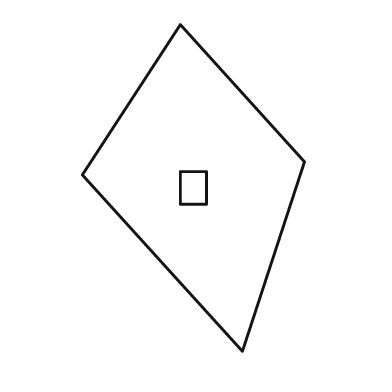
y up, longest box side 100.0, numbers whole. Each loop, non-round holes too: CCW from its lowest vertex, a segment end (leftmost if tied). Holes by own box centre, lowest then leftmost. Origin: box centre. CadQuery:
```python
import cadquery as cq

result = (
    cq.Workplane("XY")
    .moveTo(15.0, -50.0)
    .lineTo(34.0, 8.0)
    .lineTo(-4.0, 50.0)
    .lineTo(-34.0, 4.0)
    .close()
    .moveTo(-4.0, -5.0)
    .lineTo(4.0, -5.0)
    .lineTo(4.0, 5.0)
    .lineTo(-4.0, 5.0)
    .close()
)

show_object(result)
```